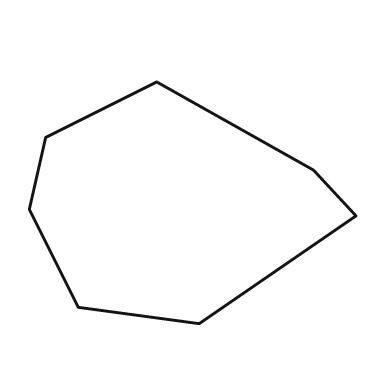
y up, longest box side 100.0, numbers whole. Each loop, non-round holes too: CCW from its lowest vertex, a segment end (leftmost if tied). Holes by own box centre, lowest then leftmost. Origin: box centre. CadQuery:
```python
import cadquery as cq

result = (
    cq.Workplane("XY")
    .moveTo(2.0, -37.0)
    .lineTo(50.0, -4.0)
    .lineTo(37.0, 10.0)
    .lineTo(-11.0, 37.0)
    .lineTo(-45.0, 20.0)
    .lineTo(-50.0, -2.0)
    .lineTo(-35.0, -32.0)
    .close()
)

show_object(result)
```